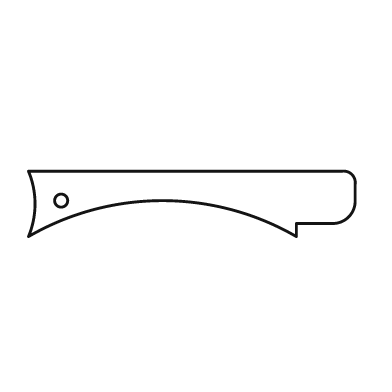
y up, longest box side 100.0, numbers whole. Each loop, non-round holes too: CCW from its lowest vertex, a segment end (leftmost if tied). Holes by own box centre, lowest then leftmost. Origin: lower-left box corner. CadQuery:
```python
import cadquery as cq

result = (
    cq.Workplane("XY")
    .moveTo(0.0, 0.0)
    .threePointArc((41.0, 11.0), (82.0, 0.0))
    .lineTo(82.0, 4.0)
    .lineTo(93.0, 4.0)
    .threePointArc((98.0, 6.0), (100.0, 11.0))
    .lineTo(100.0, 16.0)
    .threePointArc((99.0, 19.0), (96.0, 20.0))
    .lineTo(0.0, 20.0)
    .threePointArc((2.0, 10.0), (0.0, 0.0))
    .close()
    .moveTo(10.0, 11.0)
    .circle(2.0)
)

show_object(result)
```